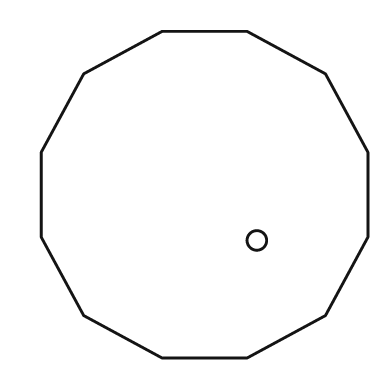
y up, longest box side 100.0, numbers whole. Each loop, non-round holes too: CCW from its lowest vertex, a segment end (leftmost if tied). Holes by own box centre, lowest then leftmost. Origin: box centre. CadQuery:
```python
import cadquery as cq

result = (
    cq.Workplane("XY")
    .moveTo(-13.0, -50.0)
    .lineTo(13.0, -50.0)
    .lineTo(37.0, -37.0)
    .lineTo(50.0, -13.0)
    .lineTo(50.0, 13.0)
    .lineTo(37.0, 37.0)
    .lineTo(13.0, 50.0)
    .lineTo(-13.0, 50.0)
    .lineTo(-37.0, 37.0)
    .lineTo(-50.0, 13.0)
    .lineTo(-50.0, -13.0)
    .lineTo(-37.0, -37.0)
    .close()
    .moveTo(16.0, -14.0)
    .circle(3.0)
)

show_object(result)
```